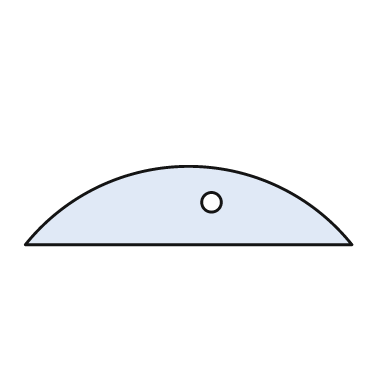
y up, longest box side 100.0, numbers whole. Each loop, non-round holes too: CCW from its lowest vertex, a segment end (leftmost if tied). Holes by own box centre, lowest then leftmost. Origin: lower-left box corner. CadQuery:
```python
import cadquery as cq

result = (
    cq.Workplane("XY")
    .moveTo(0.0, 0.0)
    .lineTo(100.0, 0.0)
    .threePointArc((50.0, 24.0), (0.0, 0.0))
    .close()
    .moveTo(57.0, 13.0)
    .circle(3.0)
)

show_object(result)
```